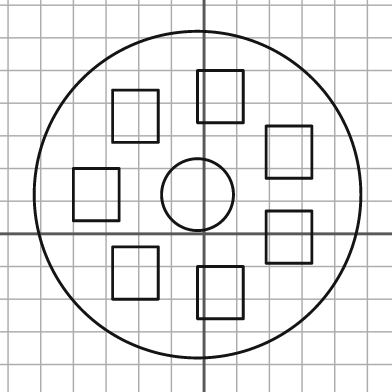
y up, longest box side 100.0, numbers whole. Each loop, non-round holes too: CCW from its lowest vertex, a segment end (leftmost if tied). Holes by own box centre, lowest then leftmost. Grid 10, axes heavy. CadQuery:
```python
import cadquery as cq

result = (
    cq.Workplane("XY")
    .moveTo(-2.0, 12.0)
    .circle(50.0)
    .moveTo(-2.0, -26.0)
    .lineTo(12.0, -26.0)
    .lineTo(12.0, -10.0)
    .lineTo(-2.0, -10.0)
    .close()
    .moveTo(-28.0, -20.0)
    .lineTo(-14.0, -20.0)
    .lineTo(-14.0, -4.0)
    .lineTo(-28.0, -4.0)
    .close()
    .moveTo(19.0, -9.0)
    .lineTo(33.0, -9.0)
    .lineTo(33.0, 7.0)
    .lineTo(19.0, 7.0)
    .close()
    .moveTo(-40.0, 4.0)
    .lineTo(-26.0, 4.0)
    .lineTo(-26.0, 20.0)
    .lineTo(-40.0, 20.0)
    .close()
    .moveTo(-2.0, 12.0)
    .circle(11.0)
    .moveTo(19.0, 17.0)
    .lineTo(33.0, 17.0)
    .lineTo(33.0, 33.0)
    .lineTo(19.0, 33.0)
    .close()
    .moveTo(-28.0, 28.0)
    .lineTo(-14.0, 28.0)
    .lineTo(-14.0, 44.0)
    .lineTo(-28.0, 44.0)
    .close()
    .moveTo(-2.0, 34.0)
    .lineTo(12.0, 34.0)
    .lineTo(12.0, 50.0)
    .lineTo(-2.0, 50.0)
    .close()
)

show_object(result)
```